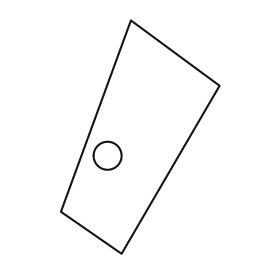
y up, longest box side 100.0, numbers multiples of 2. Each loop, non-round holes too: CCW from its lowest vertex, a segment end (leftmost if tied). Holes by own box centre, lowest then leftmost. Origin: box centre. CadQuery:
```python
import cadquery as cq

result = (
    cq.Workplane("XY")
    .moveTo(-8.0, -50.0)
    .lineTo(34.0, 22.0)
    .lineTo(-4.0, 50.0)
    .lineTo(-34.0, -32.0)
    .close()
    .moveTo(-14.0, -8.0)
    .circle(6.0)
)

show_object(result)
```